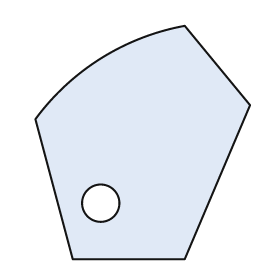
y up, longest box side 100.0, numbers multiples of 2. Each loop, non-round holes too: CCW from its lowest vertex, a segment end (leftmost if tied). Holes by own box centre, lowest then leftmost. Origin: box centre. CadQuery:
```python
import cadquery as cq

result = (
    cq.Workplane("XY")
    .moveTo(-30.0, -50.0)
    .lineTo(18.0, -50.0)
    .lineTo(46.0, 16.0)
    .lineTo(18.0, 50.0)
    .threePointArc((-18.0, 36.0), (-46.0, 10.0))
    .close()
    .moveTo(-18.0, -26.0)
    .circle(8.0)
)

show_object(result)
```